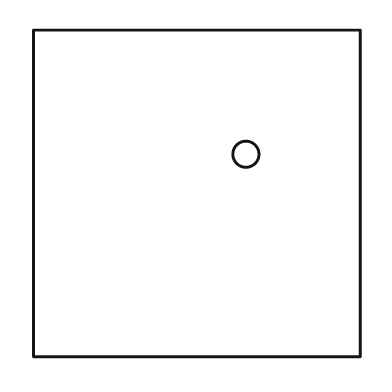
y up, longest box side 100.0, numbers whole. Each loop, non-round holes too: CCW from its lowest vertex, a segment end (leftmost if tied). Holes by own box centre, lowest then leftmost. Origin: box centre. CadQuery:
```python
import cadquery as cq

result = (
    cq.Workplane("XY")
    .moveTo(-50.0, -50.0)
    .lineTo(50.0, -50.0)
    .lineTo(50.0, 50.0)
    .lineTo(-50.0, 50.0)
    .close()
    .moveTo(15.0, 12.0)
    .circle(4.0)
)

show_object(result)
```